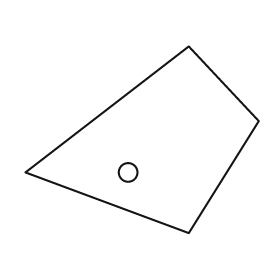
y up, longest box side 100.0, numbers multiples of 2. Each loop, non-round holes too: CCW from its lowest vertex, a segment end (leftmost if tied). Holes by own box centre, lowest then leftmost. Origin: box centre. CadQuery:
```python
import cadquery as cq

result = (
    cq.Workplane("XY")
    .moveTo(20.0, -40.0)
    .lineTo(50.0, 8.0)
    .lineTo(20.0, 40.0)
    .lineTo(-50.0, -14.0)
    .close()
    .moveTo(-6.0, -14.0)
    .circle(4.0)
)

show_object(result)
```